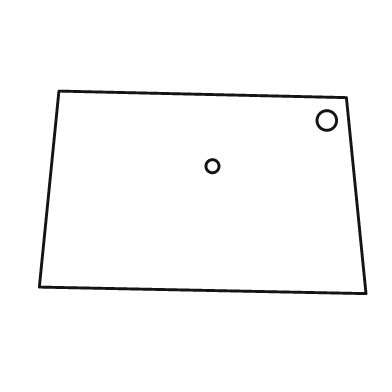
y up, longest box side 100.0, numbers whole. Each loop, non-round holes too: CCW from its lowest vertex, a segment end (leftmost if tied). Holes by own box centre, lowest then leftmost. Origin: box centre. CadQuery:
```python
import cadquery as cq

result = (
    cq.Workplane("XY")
    .moveTo(50.0, -31.0)
    .lineTo(44.0, 29.0)
    .lineTo(-44.0, 31.0)
    .lineTo(-50.0, -29.0)
    .close()
    .moveTo(3.0, 8.0)
    .circle(2.0)
    .moveTo(38.0, 22.0)
    .circle(3.0)
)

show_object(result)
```